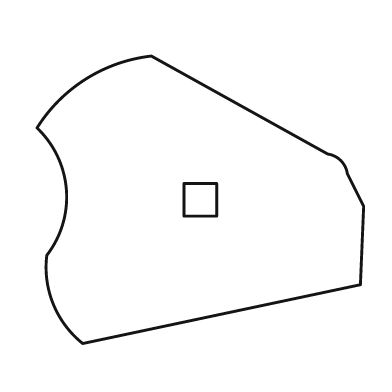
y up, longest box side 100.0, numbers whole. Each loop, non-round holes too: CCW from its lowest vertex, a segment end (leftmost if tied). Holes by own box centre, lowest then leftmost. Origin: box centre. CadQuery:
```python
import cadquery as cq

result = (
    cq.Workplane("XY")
    .moveTo(-36.0, -44.0)
    .lineTo(49.0, -26.0)
    .lineTo(50.0, -2.0)
    .lineTo(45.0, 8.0)
    .threePointArc((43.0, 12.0), (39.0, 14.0))
    .lineTo(-15.0, 44.0)
    .threePointArc((-35.0, 37.0), (-50.0, 22.0))
    .threePointArc((-41.0, 3.0), (-47.0, -17.0))
    .threePointArc((-45.0, -32.0), (-36.0, -44.0))
    .close()
    .moveTo(-5.0, -5.0)
    .lineTo(5.0, -5.0)
    .lineTo(5.0, 5.0)
    .lineTo(-5.0, 5.0)
    .close()
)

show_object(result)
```